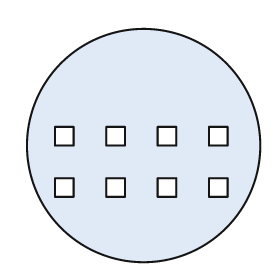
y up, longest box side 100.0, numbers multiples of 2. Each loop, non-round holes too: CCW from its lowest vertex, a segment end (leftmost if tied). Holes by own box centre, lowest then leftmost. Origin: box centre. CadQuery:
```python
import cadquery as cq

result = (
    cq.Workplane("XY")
    .moveTo(0.0, 0.0)
    .circle(50.0)
    .moveTo(-38.0, -22.0)
    .lineTo(-30.0, -22.0)
    .lineTo(-30.0, -14.0)
    .lineTo(-38.0, -14.0)
    .close()
    .moveTo(-16.0, -22.0)
    .lineTo(-8.0, -22.0)
    .lineTo(-8.0, -14.0)
    .lineTo(-16.0, -14.0)
    .close()
    .moveTo(6.0, -22.0)
    .lineTo(14.0, -22.0)
    .lineTo(14.0, -14.0)
    .lineTo(6.0, -14.0)
    .close()
    .moveTo(28.0, -22.0)
    .lineTo(36.0, -22.0)
    .lineTo(36.0, -14.0)
    .lineTo(28.0, -14.0)
    .close()
    .moveTo(-38.0, 0.0)
    .lineTo(-30.0, 0.0)
    .lineTo(-30.0, 8.0)
    .lineTo(-38.0, 8.0)
    .close()
    .moveTo(-16.0, 0.0)
    .lineTo(-8.0, 0.0)
    .lineTo(-8.0, 8.0)
    .lineTo(-16.0, 8.0)
    .close()
    .moveTo(6.0, 0.0)
    .lineTo(14.0, 0.0)
    .lineTo(14.0, 8.0)
    .lineTo(6.0, 8.0)
    .close()
    .moveTo(28.0, 0.0)
    .lineTo(36.0, 0.0)
    .lineTo(36.0, 8.0)
    .lineTo(28.0, 8.0)
    .close()
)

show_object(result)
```